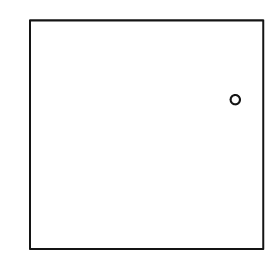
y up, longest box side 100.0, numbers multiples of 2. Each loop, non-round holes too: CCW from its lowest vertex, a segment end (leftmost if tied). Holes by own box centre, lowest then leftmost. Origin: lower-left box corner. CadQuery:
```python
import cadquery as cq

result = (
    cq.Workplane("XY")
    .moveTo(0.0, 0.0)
    .lineTo(100.0, 0.0)
    .lineTo(100.0, 98.0)
    .lineTo(0.0, 98.0)
    .close()
    .moveTo(88.0, 64.0)
    .circle(2.0)
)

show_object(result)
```